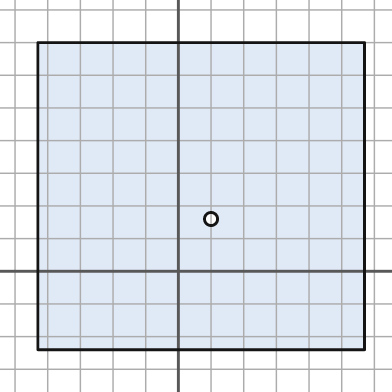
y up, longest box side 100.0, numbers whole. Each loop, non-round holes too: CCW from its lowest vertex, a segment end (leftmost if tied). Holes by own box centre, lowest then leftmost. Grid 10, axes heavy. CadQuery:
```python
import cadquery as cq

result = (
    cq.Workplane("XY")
    .moveTo(-43.0, -24.0)
    .lineTo(57.0, -24.0)
    .lineTo(57.0, 70.0)
    .lineTo(-43.0, 70.0)
    .close()
    .moveTo(10.0, 16.0)
    .circle(2.0)
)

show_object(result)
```